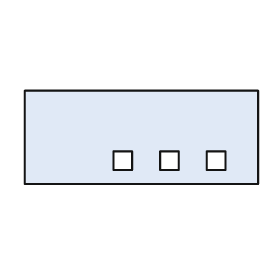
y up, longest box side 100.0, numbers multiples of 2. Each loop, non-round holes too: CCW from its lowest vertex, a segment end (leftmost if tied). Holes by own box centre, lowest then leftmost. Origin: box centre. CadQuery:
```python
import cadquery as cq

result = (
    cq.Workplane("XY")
    .moveTo(-50.0, -20.0)
    .lineTo(50.0, -20.0)
    .lineTo(50.0, 20.0)
    .lineTo(-50.0, 20.0)
    .close()
    .moveTo(-12.0, -14.0)
    .lineTo(-4.0, -14.0)
    .lineTo(-4.0, -6.0)
    .lineTo(-12.0, -6.0)
    .close()
    .moveTo(8.0, -14.0)
    .lineTo(16.0, -14.0)
    .lineTo(16.0, -6.0)
    .lineTo(8.0, -6.0)
    .close()
    .moveTo(28.0, -14.0)
    .lineTo(36.0, -14.0)
    .lineTo(36.0, -6.0)
    .lineTo(28.0, -6.0)
    .close()
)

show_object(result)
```